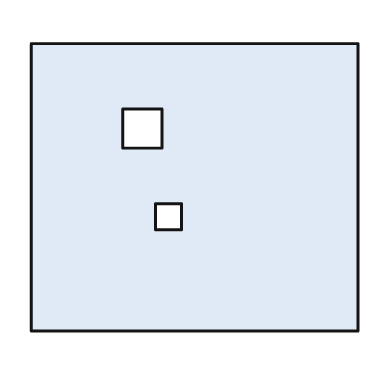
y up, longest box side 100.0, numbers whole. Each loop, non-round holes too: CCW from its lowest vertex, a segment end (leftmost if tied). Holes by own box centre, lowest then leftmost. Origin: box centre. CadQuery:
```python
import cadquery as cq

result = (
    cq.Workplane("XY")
    .moveTo(-50.0, -44.0)
    .lineTo(50.0, -44.0)
    .lineTo(50.0, 44.0)
    .lineTo(-50.0, 44.0)
    .close()
    .moveTo(-12.0, -13.0)
    .lineTo(-4.0, -13.0)
    .lineTo(-4.0, -5.0)
    .lineTo(-12.0, -5.0)
    .close()
    .moveTo(-22.0, 12.0)
    .lineTo(-10.0, 12.0)
    .lineTo(-10.0, 24.0)
    .lineTo(-22.0, 24.0)
    .close()
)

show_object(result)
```